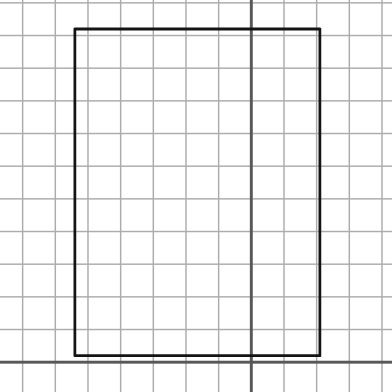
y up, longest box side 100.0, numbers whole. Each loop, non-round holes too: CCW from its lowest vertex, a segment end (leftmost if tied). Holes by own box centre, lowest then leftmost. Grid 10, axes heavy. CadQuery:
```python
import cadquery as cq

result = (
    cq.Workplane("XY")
    .moveTo(-54.0, 2.0)
    .lineTo(21.0, 2.0)
    .lineTo(21.0, 102.0)
    .lineTo(-54.0, 102.0)
    .close()
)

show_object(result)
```